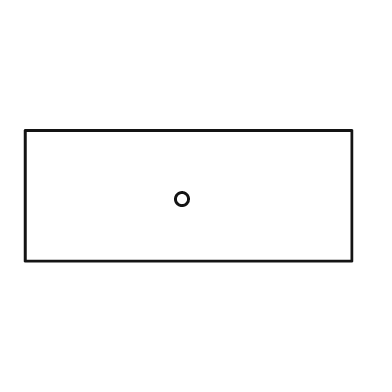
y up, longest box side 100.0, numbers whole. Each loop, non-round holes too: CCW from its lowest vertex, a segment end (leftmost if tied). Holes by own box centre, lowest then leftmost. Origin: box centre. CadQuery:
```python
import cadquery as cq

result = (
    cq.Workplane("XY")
    .moveTo(-50.0, -20.0)
    .lineTo(50.0, -20.0)
    .lineTo(50.0, 20.0)
    .lineTo(-50.0, 20.0)
    .close()
    .moveTo(-2.0, -1.0)
    .circle(2.0)
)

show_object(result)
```